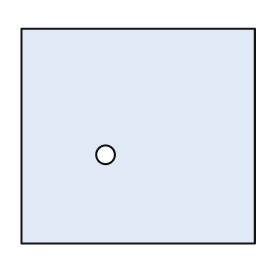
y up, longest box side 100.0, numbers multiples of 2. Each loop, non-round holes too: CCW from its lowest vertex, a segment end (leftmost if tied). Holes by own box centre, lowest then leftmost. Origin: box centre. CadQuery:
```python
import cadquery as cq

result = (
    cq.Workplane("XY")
    .moveTo(-50.0, -46.0)
    .lineTo(50.0, -46.0)
    .lineTo(50.0, 46.0)
    .lineTo(-50.0, 46.0)
    .close()
    .moveTo(-14.0, -8.0)
    .circle(4.0)
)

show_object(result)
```